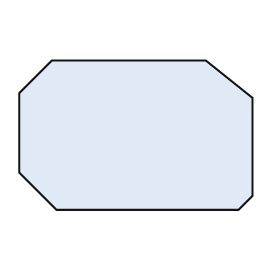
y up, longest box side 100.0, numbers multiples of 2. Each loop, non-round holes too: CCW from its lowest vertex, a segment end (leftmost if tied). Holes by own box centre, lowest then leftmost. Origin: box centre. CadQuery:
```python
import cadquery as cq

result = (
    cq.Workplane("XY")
    .moveTo(-34.0, -32.0)
    .lineTo(44.0, -32.0)
    .lineTo(50.0, -26.0)
    .lineTo(50.0, 16.0)
    .lineTo(30.0, 32.0)
    .lineTo(-36.0, 32.0)
    .lineTo(-50.0, 18.0)
    .lineTo(-50.0, -16.0)
    .close()
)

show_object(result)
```